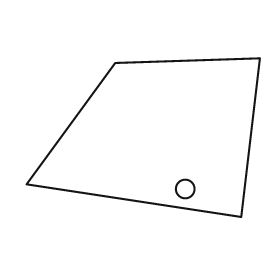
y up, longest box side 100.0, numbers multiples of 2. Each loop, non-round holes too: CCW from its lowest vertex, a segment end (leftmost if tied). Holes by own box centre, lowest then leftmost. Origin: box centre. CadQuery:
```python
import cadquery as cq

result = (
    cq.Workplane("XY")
    .moveTo(42.0, -34.0)
    .lineTo(50.0, 34.0)
    .lineTo(-12.0, 32.0)
    .lineTo(-50.0, -20.0)
    .close()
    .moveTo(18.0, -22.0)
    .circle(4.0)
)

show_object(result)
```